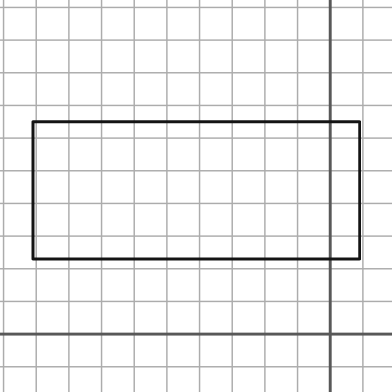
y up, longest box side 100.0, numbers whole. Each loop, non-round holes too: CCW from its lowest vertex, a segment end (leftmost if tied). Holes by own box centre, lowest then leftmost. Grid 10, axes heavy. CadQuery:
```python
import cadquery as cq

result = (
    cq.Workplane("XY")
    .moveTo(-91.0, 23.0)
    .lineTo(9.0, 23.0)
    .lineTo(9.0, 65.0)
    .lineTo(-91.0, 65.0)
    .close()
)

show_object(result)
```